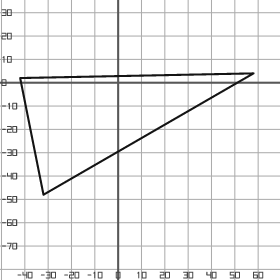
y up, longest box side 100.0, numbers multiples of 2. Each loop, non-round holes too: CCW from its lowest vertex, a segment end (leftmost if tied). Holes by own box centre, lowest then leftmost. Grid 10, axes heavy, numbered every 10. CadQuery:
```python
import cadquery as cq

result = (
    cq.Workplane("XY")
    .moveTo(-32.0, -48.0)
    .lineTo(58.0, 4.0)
    .lineTo(-42.0, 2.0)
    .close()
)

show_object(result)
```